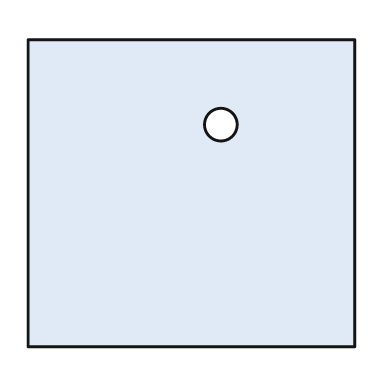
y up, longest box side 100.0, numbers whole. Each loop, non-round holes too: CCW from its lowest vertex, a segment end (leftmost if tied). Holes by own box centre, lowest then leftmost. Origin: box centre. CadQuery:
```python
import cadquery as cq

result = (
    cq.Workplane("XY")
    .moveTo(-50.0, -47.0)
    .lineTo(50.0, -47.0)
    .lineTo(50.0, 47.0)
    .lineTo(-50.0, 47.0)
    .close()
    .moveTo(9.0, 21.0)
    .circle(5.0)
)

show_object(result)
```